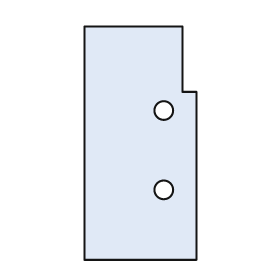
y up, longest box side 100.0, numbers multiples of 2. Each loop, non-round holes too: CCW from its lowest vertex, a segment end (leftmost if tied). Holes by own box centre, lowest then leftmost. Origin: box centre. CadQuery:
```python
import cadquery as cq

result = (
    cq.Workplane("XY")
    .moveTo(-24.0, -50.0)
    .lineTo(24.0, -50.0)
    .lineTo(24.0, 22.0)
    .lineTo(18.0, 22.0)
    .lineTo(18.0, 50.0)
    .lineTo(-24.0, 50.0)
    .close()
    .moveTo(10.0, -20.0)
    .circle(4.0)
    .moveTo(10.0, 14.0)
    .circle(4.0)
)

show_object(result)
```